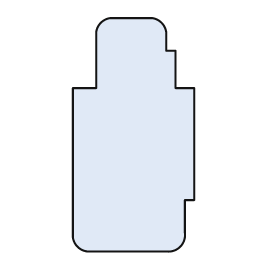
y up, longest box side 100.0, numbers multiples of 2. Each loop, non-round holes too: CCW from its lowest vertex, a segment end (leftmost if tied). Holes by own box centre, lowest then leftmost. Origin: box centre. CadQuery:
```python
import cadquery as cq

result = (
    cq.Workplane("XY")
    .moveTo(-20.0, -50.0)
    .lineTo(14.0, -50.0)
    .threePointArc((20.0, -48.0), (22.0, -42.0))
    .lineTo(22.0, -28.0)
    .lineTo(26.0, -28.0)
    .lineTo(26.0, 20.0)
    .lineTo(18.0, 20.0)
    .lineTo(18.0, 36.0)
    .lineTo(14.0, 36.0)
    .lineTo(14.0, 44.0)
    .threePointArc((12.0, 48.0), (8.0, 50.0))
    .lineTo(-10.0, 50.0)
    .threePointArc((-14.0, 48.0), (-16.0, 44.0))
    .lineTo(-16.0, 20.0)
    .lineTo(-26.0, 20.0)
    .lineTo(-26.0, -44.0)
    .threePointArc((-24.0, -48.0), (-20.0, -50.0))
    .close()
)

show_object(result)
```